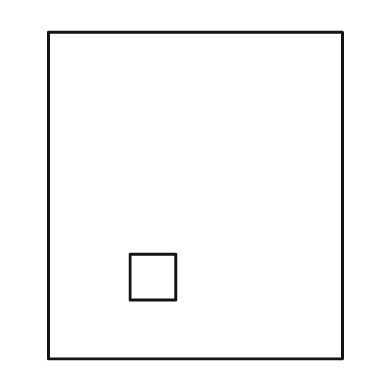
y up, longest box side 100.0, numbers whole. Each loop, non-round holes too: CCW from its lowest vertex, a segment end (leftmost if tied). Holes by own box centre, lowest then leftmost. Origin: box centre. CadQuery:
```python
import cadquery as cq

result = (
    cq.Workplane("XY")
    .moveTo(-45.0, -50.0)
    .lineTo(45.0, -50.0)
    .lineTo(45.0, 50.0)
    .lineTo(-45.0, 50.0)
    .close()
    .moveTo(-20.0, -32.0)
    .lineTo(-6.0, -32.0)
    .lineTo(-6.0, -18.0)
    .lineTo(-20.0, -18.0)
    .close()
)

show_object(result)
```